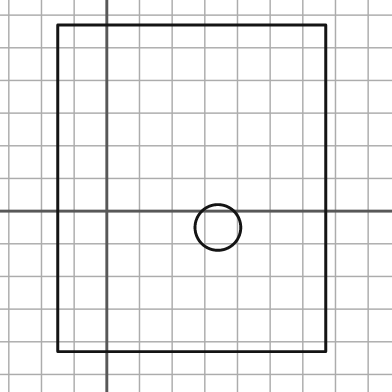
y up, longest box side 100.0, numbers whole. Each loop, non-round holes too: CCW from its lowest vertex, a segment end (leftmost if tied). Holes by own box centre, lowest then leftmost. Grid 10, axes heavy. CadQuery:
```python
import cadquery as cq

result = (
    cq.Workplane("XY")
    .moveTo(-15.0, -43.0)
    .lineTo(67.0, -43.0)
    .lineTo(67.0, 57.0)
    .lineTo(-15.0, 57.0)
    .close()
    .moveTo(34.0, -5.0)
    .circle(7.0)
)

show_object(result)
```